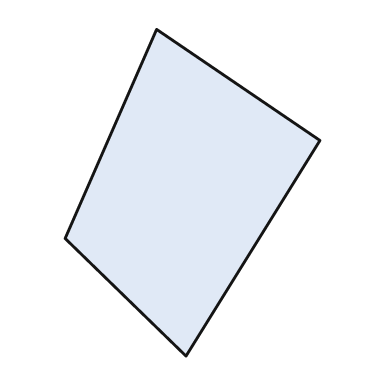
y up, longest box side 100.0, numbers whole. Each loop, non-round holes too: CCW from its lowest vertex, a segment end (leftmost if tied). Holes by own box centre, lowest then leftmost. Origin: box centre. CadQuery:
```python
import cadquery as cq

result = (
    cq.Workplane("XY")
    .moveTo(-2.0, -50.0)
    .lineTo(39.0, 16.0)
    .lineTo(-11.0, 50.0)
    .lineTo(-39.0, -14.0)
    .close()
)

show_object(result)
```